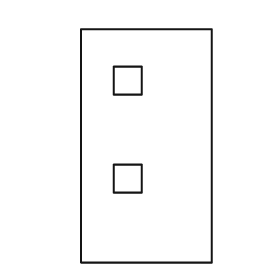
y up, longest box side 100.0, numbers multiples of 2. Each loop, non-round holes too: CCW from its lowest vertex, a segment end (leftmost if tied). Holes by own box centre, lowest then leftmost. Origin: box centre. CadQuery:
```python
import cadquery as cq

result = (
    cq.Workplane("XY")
    .moveTo(-28.0, -50.0)
    .lineTo(28.0, -50.0)
    .lineTo(28.0, 50.0)
    .lineTo(-28.0, 50.0)
    .close()
    .moveTo(-14.0, -20.0)
    .lineTo(-2.0, -20.0)
    .lineTo(-2.0, -8.0)
    .lineTo(-14.0, -8.0)
    .close()
    .moveTo(-14.0, 22.0)
    .lineTo(-2.0, 22.0)
    .lineTo(-2.0, 34.0)
    .lineTo(-14.0, 34.0)
    .close()
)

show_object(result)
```